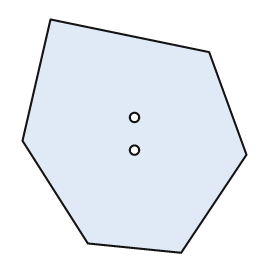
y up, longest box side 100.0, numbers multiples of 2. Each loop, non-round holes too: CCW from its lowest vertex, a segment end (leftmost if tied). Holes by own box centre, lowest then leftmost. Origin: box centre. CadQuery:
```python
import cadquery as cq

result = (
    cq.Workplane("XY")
    .moveTo(20.0, -50.0)
    .lineTo(48.0, -8.0)
    .lineTo(32.0, 36.0)
    .lineTo(-36.0, 50.0)
    .lineTo(-48.0, -2.0)
    .lineTo(-20.0, -46.0)
    .close()
    .moveTo(0.0, -6.0)
    .circle(2.0)
    .moveTo(0.0, 8.0)
    .circle(2.0)
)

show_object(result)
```